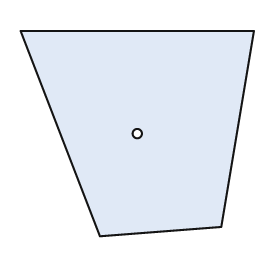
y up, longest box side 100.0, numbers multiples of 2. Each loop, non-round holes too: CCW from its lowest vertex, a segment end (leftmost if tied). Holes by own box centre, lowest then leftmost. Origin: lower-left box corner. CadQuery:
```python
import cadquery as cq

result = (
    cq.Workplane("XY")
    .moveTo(34.0, 0.0)
    .lineTo(86.0, 4.0)
    .lineTo(100.0, 88.0)
    .lineTo(0.0, 88.0)
    .close()
    .moveTo(50.0, 44.0)
    .circle(2.0)
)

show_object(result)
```